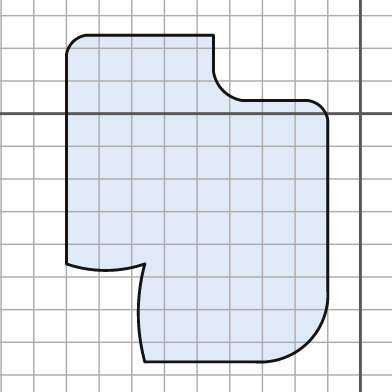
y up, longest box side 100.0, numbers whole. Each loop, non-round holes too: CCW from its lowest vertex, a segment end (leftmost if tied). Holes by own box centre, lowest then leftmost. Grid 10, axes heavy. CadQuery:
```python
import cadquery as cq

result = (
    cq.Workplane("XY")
    .moveTo(-66.0, -76.0)
    .lineTo(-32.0, -76.0)
    .threePointArc((-16.0, -70.0), (-10.0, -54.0))
    .lineTo(-10.0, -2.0)
    .threePointArc((-12.0, 2.0), (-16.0, 4.0))
    .lineTo(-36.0, 4.0)
    .threePointArc((-42.0, 7.0), (-45.0, 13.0))
    .lineTo(-45.0, 24.0)
    .lineTo(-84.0, 24.0)
    .threePointArc((-88.0, 22.0), (-90.0, 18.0))
    .lineTo(-90.0, -46.0)
    .threePointArc((-78.0, -48.0), (-66.0, -46.0))
    .threePointArc((-68.0, -61.0), (-66.0, -76.0))
    .close()
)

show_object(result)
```